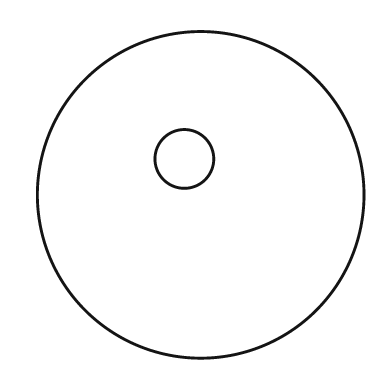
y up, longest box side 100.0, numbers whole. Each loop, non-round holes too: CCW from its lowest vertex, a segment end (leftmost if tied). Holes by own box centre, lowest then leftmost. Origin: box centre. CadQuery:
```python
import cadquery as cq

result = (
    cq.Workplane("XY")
    .moveTo(0.0, 0.0)
    .circle(50.0)
    .moveTo(-5.0, 11.0)
    .circle(9.0)
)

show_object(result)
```